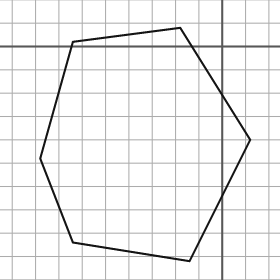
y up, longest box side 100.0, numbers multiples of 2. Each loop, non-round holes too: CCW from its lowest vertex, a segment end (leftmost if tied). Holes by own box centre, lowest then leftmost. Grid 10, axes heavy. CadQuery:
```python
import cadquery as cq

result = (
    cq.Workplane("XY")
    .moveTo(-14.0, -92.0)
    .lineTo(12.0, -40.0)
    .lineTo(-18.0, 8.0)
    .lineTo(-64.0, 2.0)
    .lineTo(-78.0, -48.0)
    .lineTo(-64.0, -84.0)
    .close()
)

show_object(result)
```